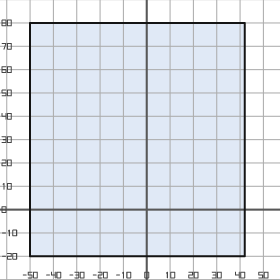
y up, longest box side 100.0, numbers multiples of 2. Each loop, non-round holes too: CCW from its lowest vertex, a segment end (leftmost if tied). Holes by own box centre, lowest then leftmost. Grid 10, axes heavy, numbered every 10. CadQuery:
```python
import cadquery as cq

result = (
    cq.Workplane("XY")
    .moveTo(-50.0, -20.0)
    .lineTo(42.0, -20.0)
    .lineTo(42.0, 80.0)
    .lineTo(-50.0, 80.0)
    .close()
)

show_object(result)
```